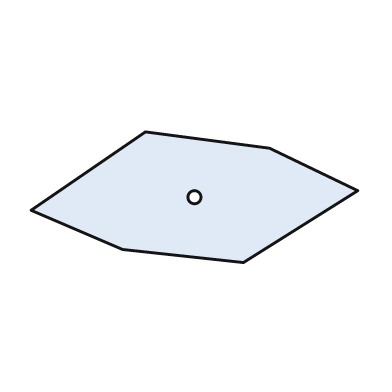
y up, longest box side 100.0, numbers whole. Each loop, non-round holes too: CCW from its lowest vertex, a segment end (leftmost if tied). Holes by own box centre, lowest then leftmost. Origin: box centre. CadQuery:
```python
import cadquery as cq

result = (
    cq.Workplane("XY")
    .moveTo(15.0, -20.0)
    .lineTo(50.0, 2.0)
    .lineTo(23.0, 15.0)
    .lineTo(-15.0, 20.0)
    .lineTo(-50.0, -4.0)
    .lineTo(-22.0, -16.0)
    .close()
    .moveTo(0.0, 0.0)
    .circle(2.0)
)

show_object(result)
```